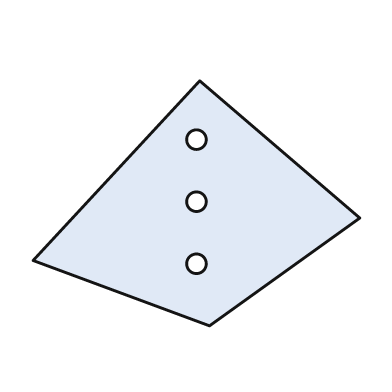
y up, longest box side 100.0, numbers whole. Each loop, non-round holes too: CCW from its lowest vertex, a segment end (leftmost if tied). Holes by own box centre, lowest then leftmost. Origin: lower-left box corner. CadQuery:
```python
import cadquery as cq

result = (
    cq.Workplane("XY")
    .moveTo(54.0, 0.0)
    .lineTo(100.0, 33.0)
    .lineTo(51.0, 75.0)
    .lineTo(0.0, 20.0)
    .close()
    .moveTo(50.0, 19.0)
    .circle(3.0)
    .moveTo(50.0, 38.0)
    .circle(3.0)
    .moveTo(50.0, 57.0)
    .circle(3.0)
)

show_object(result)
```